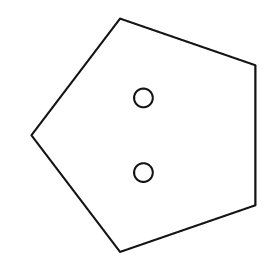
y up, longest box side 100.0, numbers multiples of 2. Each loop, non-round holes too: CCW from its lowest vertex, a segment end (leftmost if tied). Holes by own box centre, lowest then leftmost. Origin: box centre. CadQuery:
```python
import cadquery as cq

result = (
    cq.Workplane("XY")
    .moveTo(-10.0, -50.0)
    .lineTo(48.0, -30.0)
    .lineTo(48.0, 30.0)
    .lineTo(-10.0, 50.0)
    .lineTo(-48.0, 0.0)
    .close()
    .moveTo(0.0, -16.0)
    .circle(4.0)
    .moveTo(0.0, 16.0)
    .circle(4.0)
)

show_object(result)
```